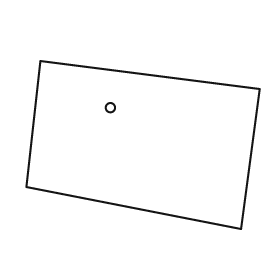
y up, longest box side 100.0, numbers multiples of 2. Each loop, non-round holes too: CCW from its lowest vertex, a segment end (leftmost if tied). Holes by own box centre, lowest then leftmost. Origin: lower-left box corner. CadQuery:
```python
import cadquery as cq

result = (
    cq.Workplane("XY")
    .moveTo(92.0, 0.0)
    .lineTo(100.0, 60.0)
    .lineTo(6.0, 72.0)
    .lineTo(0.0, 18.0)
    .close()
    .moveTo(36.0, 52.0)
    .circle(2.0)
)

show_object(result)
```